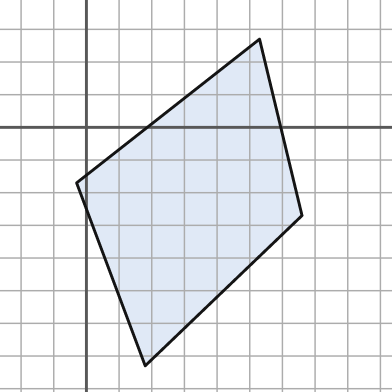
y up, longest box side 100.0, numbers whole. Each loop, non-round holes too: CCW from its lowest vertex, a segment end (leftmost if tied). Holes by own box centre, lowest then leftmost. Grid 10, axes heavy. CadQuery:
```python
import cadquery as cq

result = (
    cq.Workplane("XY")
    .moveTo(18.0, -73.0)
    .lineTo(66.0, -27.0)
    .lineTo(53.0, 27.0)
    .lineTo(-3.0, -17.0)
    .close()
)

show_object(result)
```